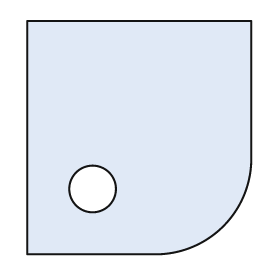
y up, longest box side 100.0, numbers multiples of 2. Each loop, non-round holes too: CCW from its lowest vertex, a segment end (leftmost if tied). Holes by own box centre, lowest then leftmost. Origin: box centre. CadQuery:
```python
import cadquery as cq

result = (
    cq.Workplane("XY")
    .moveTo(-48.0, -50.0)
    .lineTo(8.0, -50.0)
    .threePointArc((36.0, -38.0), (48.0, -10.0))
    .lineTo(48.0, 50.0)
    .lineTo(-48.0, 50.0)
    .close()
    .moveTo(-20.0, -22.0)
    .circle(10.0)
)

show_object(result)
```